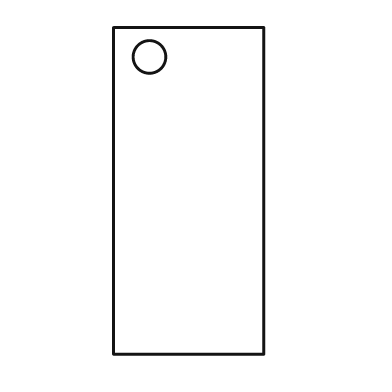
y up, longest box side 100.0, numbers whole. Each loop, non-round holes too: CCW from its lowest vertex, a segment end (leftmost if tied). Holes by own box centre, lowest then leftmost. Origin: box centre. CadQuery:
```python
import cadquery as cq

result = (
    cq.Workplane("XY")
    .moveTo(-23.0, -50.0)
    .lineTo(23.0, -50.0)
    .lineTo(23.0, 50.0)
    .lineTo(-23.0, 50.0)
    .close()
    .moveTo(-12.0, 41.0)
    .circle(5.0)
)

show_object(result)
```